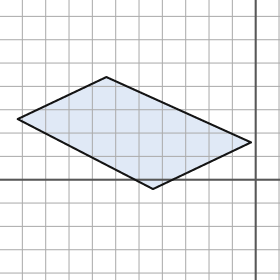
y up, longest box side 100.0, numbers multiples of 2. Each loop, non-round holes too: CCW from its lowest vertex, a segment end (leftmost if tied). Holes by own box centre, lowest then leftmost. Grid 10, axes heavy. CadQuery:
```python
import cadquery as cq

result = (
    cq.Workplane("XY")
    .moveTo(-44.0, -4.0)
    .lineTo(-2.0, 16.0)
    .lineTo(-64.0, 44.0)
    .lineTo(-102.0, 26.0)
    .close()
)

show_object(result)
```